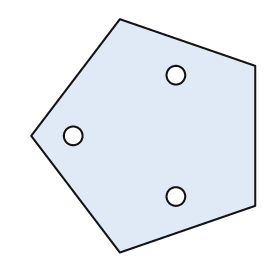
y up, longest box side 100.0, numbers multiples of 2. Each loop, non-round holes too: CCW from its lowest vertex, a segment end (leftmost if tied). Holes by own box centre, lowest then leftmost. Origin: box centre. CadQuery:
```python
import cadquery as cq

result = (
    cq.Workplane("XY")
    .moveTo(-10.0, -50.0)
    .lineTo(48.0, -30.0)
    .lineTo(48.0, 30.0)
    .lineTo(-10.0, 50.0)
    .lineTo(-48.0, 0.0)
    .close()
    .moveTo(14.0, -26.0)
    .circle(4.0)
    .moveTo(-30.0, 0.0)
    .circle(4.0)
    .moveTo(14.0, 26.0)
    .circle(4.0)
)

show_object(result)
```